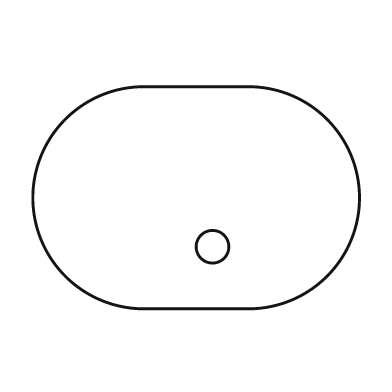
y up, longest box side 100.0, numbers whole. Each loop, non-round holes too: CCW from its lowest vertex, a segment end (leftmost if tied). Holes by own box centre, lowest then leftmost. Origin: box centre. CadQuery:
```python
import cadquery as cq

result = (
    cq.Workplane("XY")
    .moveTo(-16.0, -34.0)
    .lineTo(16.0, -34.0)
    .threePointArc((50.0, 0.0), (16.0, 34.0))
    .lineTo(-16.0, 34.0)
    .threePointArc((-50.0, 0.0), (-16.0, -34.0))
    .close()
    .moveTo(5.0, -15.0)
    .circle(5.0)
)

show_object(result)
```